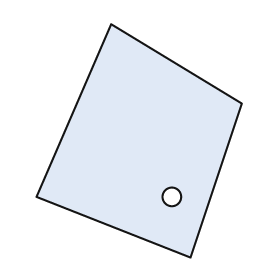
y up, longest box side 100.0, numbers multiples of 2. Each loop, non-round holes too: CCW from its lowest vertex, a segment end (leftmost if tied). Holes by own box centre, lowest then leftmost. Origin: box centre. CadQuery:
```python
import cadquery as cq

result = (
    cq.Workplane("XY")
    .moveTo(22.0, -50.0)
    .lineTo(44.0, 16.0)
    .lineTo(-12.0, 50.0)
    .lineTo(-44.0, -24.0)
    .close()
    .moveTo(14.0, -24.0)
    .circle(4.0)
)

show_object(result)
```